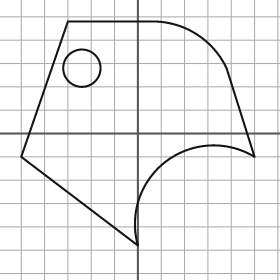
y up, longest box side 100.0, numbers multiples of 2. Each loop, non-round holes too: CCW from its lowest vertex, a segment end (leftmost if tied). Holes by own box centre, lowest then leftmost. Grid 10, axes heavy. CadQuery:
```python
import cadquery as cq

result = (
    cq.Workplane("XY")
    .moveTo(0.0, -48.0)
    .threePointArc((12.0, -12.0), (50.0, -10.0))
    .lineTo(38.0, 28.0)
    .threePointArc((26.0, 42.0), (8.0, 48.0))
    .lineTo(-30.0, 48.0)
    .lineTo(-50.0, -10.0)
    .close()
    .moveTo(-24.0, 28.0)
    .circle(8.0)
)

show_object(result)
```